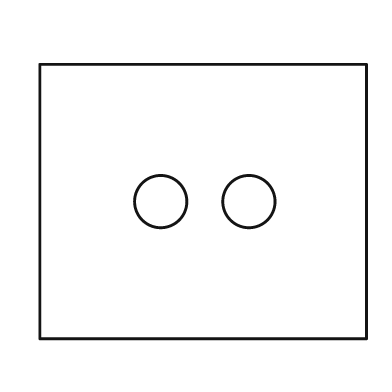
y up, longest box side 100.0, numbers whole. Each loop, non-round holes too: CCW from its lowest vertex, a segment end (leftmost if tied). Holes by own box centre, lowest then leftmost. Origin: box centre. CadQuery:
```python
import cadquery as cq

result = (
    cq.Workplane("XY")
    .moveTo(-50.0, -42.0)
    .lineTo(50.0, -42.0)
    .lineTo(50.0, 42.0)
    .lineTo(-50.0, 42.0)
    .close()
    .moveTo(-13.0, 0.0)
    .circle(8.0)
    .moveTo(14.0, 0.0)
    .circle(8.0)
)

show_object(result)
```